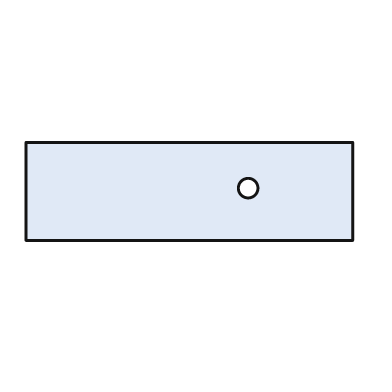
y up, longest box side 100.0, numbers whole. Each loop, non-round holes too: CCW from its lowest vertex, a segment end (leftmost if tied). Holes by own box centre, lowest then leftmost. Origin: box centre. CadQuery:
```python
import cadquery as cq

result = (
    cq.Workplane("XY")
    .moveTo(-50.0, -15.0)
    .lineTo(50.0, -15.0)
    .lineTo(50.0, 15.0)
    .lineTo(-50.0, 15.0)
    .close()
    .moveTo(18.0, 1.0)
    .circle(3.0)
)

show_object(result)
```